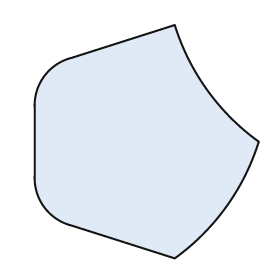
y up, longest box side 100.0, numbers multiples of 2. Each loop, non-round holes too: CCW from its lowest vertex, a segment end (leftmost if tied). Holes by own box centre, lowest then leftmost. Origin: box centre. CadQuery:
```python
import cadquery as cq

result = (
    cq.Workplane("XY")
    .moveTo(12.0, -50.0)
    .threePointArc((34.0, -28.0), (48.0, 0.0))
    .threePointArc((26.0, 22.0), (12.0, 50.0))
    .lineTo(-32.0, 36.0)
    .threePointArc((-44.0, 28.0), (-48.0, 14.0))
    .lineTo(-48.0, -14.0)
    .threePointArc((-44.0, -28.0), (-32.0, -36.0))
    .close()
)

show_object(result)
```